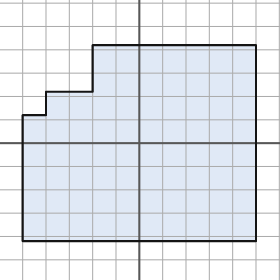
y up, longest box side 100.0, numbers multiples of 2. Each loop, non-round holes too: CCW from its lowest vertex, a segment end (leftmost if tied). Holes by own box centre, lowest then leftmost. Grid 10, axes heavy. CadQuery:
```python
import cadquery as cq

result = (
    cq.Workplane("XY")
    .moveTo(-50.0, -42.0)
    .lineTo(50.0, -42.0)
    .lineTo(50.0, 42.0)
    .lineTo(-20.0, 42.0)
    .lineTo(-20.0, 22.0)
    .lineTo(-40.0, 22.0)
    .lineTo(-40.0, 12.0)
    .lineTo(-50.0, 12.0)
    .close()
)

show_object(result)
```